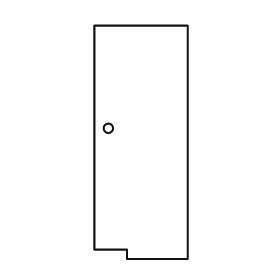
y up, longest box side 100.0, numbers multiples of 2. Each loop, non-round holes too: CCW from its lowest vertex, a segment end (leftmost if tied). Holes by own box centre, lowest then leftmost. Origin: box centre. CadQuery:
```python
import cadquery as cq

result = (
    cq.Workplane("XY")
    .moveTo(-6.0, -50.0)
    .lineTo(20.0, -50.0)
    .lineTo(20.0, 50.0)
    .lineTo(-20.0, 50.0)
    .lineTo(-20.0, -46.0)
    .lineTo(-6.0, -46.0)
    .close()
    .moveTo(-14.0, 6.0)
    .circle(2.0)
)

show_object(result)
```